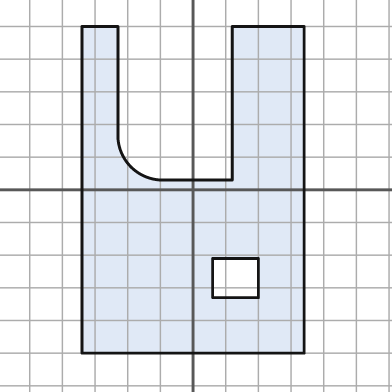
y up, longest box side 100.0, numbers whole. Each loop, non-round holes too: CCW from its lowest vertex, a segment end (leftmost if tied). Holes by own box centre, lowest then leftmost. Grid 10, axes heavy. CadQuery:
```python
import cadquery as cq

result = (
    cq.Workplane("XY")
    .moveTo(-34.0, -50.0)
    .lineTo(34.0, -50.0)
    .lineTo(34.0, 50.0)
    .lineTo(12.0, 50.0)
    .lineTo(12.0, 3.0)
    .lineTo(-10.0, 3.0)
    .threePointArc((-19.0, 7.0), (-23.0, 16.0))
    .lineTo(-23.0, 50.0)
    .lineTo(-34.0, 50.0)
    .close()
    .moveTo(6.0, -33.0)
    .lineTo(20.0, -33.0)
    .lineTo(20.0, -21.0)
    .lineTo(6.0, -21.0)
    .close()
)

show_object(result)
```